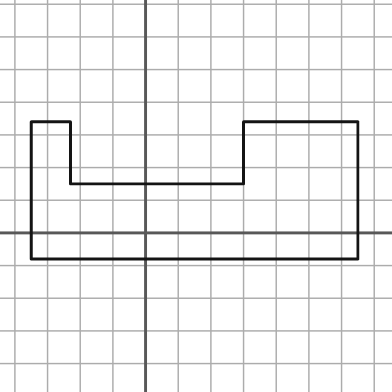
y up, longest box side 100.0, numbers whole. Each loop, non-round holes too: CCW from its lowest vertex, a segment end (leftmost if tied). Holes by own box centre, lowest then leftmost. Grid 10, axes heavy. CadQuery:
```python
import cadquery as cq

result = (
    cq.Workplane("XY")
    .moveTo(-35.0, -8.0)
    .lineTo(65.0, -8.0)
    .lineTo(65.0, 34.0)
    .lineTo(30.0, 34.0)
    .lineTo(30.0, 15.0)
    .lineTo(-23.0, 15.0)
    .lineTo(-23.0, 34.0)
    .lineTo(-35.0, 34.0)
    .close()
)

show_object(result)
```